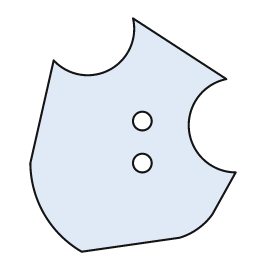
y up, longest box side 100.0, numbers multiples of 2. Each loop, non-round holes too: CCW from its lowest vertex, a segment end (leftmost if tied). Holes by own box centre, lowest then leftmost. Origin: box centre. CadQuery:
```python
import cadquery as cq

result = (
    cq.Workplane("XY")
    .moveTo(-22.0, -50.0)
    .lineTo(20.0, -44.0)
    .threePointArc((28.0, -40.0), (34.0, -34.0))
    .lineTo(44.0, -16.0)
    .threePointArc((24.0, 2.0), (40.0, 24.0))
    .lineTo(0.0, 50.0)
    .threePointArc((-10.0, 28.0), (-34.0, 32.0))
    .lineTo(-44.0, -12.0)
    .threePointArc((-38.0, -34.0), (-22.0, -50.0))
    .close()
    .moveTo(4.0, -12.0)
    .circle(4.0)
    .moveTo(4.0, 6.0)
    .circle(4.0)
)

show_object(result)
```